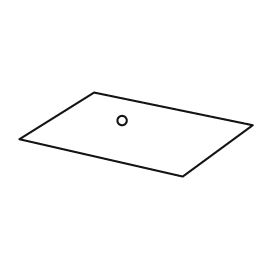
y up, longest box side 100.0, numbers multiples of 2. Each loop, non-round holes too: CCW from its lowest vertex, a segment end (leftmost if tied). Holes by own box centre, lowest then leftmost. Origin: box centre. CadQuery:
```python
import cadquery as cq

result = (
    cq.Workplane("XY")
    .moveTo(20.0, -18.0)
    .lineTo(50.0, 4.0)
    .lineTo(-18.0, 18.0)
    .lineTo(-50.0, -2.0)
    .close()
    .moveTo(-6.0, 6.0)
    .circle(2.0)
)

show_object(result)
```